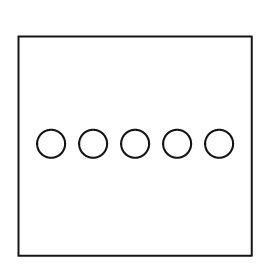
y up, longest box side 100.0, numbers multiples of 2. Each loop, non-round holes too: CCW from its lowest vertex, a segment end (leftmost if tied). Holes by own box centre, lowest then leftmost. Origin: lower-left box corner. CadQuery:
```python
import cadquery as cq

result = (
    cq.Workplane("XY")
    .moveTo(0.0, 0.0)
    .lineTo(100.0, 0.0)
    .lineTo(100.0, 94.0)
    .lineTo(0.0, 94.0)
    .close()
    .moveTo(14.0, 48.0)
    .circle(6.0)
    .moveTo(32.0, 48.0)
    .circle(6.0)
    .moveTo(50.0, 48.0)
    .circle(6.0)
    .moveTo(68.0, 48.0)
    .circle(6.0)
    .moveTo(86.0, 48.0)
    .circle(6.0)
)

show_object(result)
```